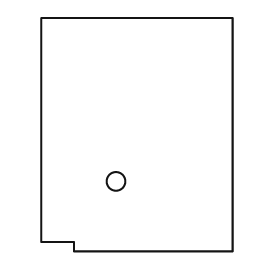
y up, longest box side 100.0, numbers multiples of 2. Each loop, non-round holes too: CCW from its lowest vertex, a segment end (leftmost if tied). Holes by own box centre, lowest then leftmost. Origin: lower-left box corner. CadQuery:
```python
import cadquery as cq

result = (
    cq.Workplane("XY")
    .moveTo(14.0, 0.0)
    .lineTo(82.0, 0.0)
    .lineTo(82.0, 100.0)
    .lineTo(0.0, 100.0)
    .lineTo(0.0, 4.0)
    .lineTo(14.0, 4.0)
    .close()
    .moveTo(32.0, 30.0)
    .circle(4.0)
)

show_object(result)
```